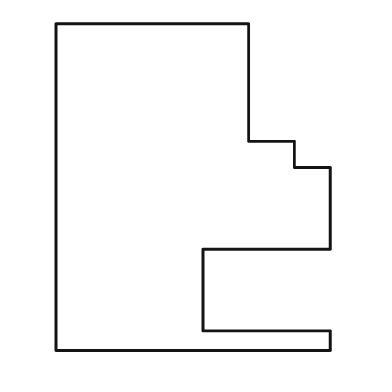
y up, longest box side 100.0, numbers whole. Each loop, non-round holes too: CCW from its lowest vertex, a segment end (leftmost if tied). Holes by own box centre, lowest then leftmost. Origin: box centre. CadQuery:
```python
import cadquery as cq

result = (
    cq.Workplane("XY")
    .moveTo(-42.0, -50.0)
    .lineTo(42.0, -50.0)
    .lineTo(42.0, -44.0)
    .lineTo(3.0, -44.0)
    .lineTo(3.0, -19.0)
    .lineTo(42.0, -19.0)
    .lineTo(42.0, 6.0)
    .lineTo(31.0, 6.0)
    .lineTo(31.0, 14.0)
    .lineTo(17.0, 14.0)
    .lineTo(17.0, 50.0)
    .lineTo(-42.0, 50.0)
    .close()
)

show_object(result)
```